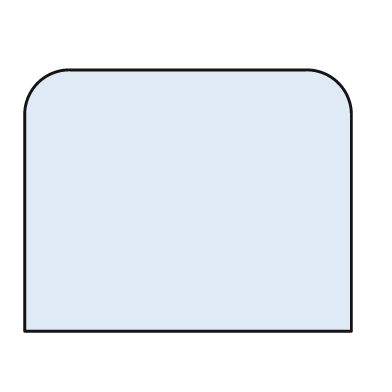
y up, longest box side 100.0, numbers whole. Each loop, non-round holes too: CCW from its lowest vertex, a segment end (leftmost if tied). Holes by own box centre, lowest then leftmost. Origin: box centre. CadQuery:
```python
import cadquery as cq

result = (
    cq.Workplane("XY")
    .moveTo(-50.0, -40.0)
    .lineTo(50.0, -40.0)
    .lineTo(50.0, 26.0)
    .threePointArc((46.0, 36.0), (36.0, 40.0))
    .lineTo(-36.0, 40.0)
    .threePointArc((-46.0, 36.0), (-50.0, 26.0))
    .close()
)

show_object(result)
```